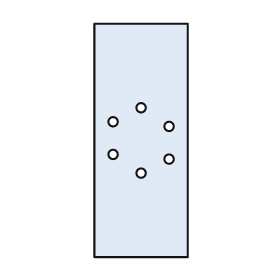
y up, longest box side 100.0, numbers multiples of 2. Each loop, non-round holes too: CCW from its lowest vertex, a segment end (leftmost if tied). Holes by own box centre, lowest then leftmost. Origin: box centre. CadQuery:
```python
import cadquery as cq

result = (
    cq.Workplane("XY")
    .moveTo(-20.0, -50.0)
    .lineTo(20.0, -50.0)
    .lineTo(20.0, 50.0)
    .lineTo(-20.0, 50.0)
    .close()
    .moveTo(0.0, -14.0)
    .circle(2.0)
    .moveTo(12.0, -8.0)
    .circle(2.0)
    .moveTo(-12.0, -6.0)
    .circle(2.0)
    .moveTo(12.0, 6.0)
    .circle(2.0)
    .moveTo(-12.0, 8.0)
    .circle(2.0)
    .moveTo(0.0, 14.0)
    .circle(2.0)
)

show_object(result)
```